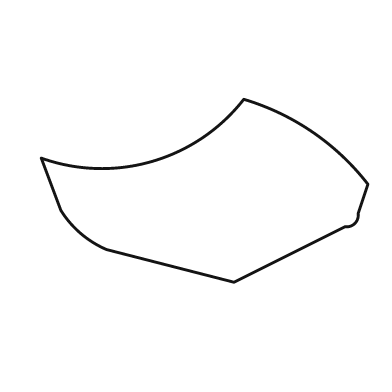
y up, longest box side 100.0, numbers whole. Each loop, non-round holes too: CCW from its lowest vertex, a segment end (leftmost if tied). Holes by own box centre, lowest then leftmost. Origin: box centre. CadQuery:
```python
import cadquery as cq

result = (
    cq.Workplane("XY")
    .moveTo(9.0, -28.0)
    .lineTo(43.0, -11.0)
    .threePointArc((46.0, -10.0), (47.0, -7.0))
    .lineTo(50.0, 2.0)
    .threePointArc((33.0, 18.0), (12.0, 28.0))
    .threePointArc((-16.0, 9.0), (-50.0, 10.0))
    .lineTo(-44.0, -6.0)
    .threePointArc((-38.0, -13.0), (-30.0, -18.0))
    .close()
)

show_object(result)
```